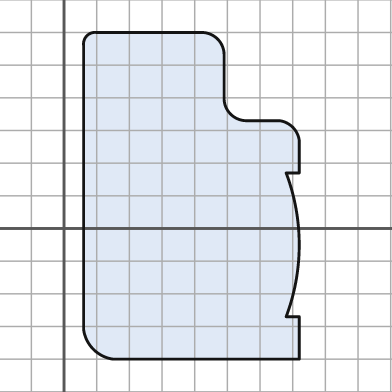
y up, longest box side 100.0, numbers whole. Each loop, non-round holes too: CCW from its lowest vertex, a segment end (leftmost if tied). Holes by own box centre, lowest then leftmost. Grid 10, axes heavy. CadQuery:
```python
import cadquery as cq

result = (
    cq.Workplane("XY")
    .moveTo(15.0, -40.0)
    .lineTo(72.0, -40.0)
    .lineTo(72.0, -27.0)
    .lineTo(68.0, -27.0)
    .threePointArc((72.0, -5.0), (68.0, 17.0))
    .lineTo(72.0, 17.0)
    .lineTo(72.0, 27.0)
    .threePointArc((70.0, 31.0), (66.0, 33.0))
    .lineTo(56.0, 33.0)
    .threePointArc((51.0, 35.0), (49.0, 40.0))
    .lineTo(49.0, 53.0)
    .threePointArc((47.0, 58.0), (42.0, 60.0))
    .lineTo(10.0, 60.0)
    .threePointArc((7.0, 59.0), (6.0, 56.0))
    .lineTo(6.0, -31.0)
    .threePointArc((9.0, -37.0), (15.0, -40.0))
    .close()
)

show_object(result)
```